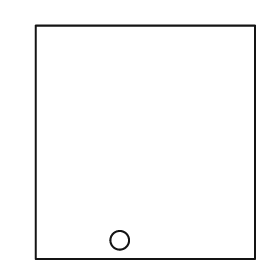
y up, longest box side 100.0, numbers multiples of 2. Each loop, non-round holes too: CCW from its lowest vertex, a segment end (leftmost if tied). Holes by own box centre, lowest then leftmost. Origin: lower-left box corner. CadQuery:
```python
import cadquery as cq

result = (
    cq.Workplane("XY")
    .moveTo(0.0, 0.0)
    .lineTo(94.0, 0.0)
    .lineTo(94.0, 100.0)
    .lineTo(0.0, 100.0)
    .close()
    .moveTo(36.0, 8.0)
    .circle(4.0)
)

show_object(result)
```